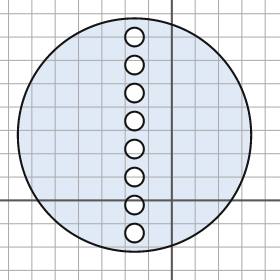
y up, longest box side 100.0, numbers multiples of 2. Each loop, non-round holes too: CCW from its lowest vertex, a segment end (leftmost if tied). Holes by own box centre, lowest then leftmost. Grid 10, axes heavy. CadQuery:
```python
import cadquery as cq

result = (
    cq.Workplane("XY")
    .moveTo(-16.0, 28.0)
    .circle(50.0)
    .moveTo(-16.0, -14.0)
    .circle(4.0)
    .moveTo(-16.0, -2.0)
    .circle(4.0)
    .moveTo(-16.0, 10.0)
    .circle(4.0)
    .moveTo(-16.0, 22.0)
    .circle(4.0)
    .moveTo(-16.0, 34.0)
    .circle(4.0)
    .moveTo(-16.0, 46.0)
    .circle(4.0)
    .moveTo(-16.0, 58.0)
    .circle(4.0)
    .moveTo(-16.0, 70.0)
    .circle(4.0)
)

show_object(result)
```